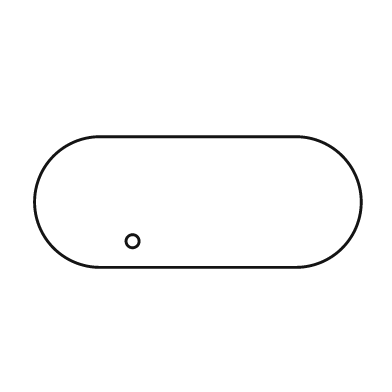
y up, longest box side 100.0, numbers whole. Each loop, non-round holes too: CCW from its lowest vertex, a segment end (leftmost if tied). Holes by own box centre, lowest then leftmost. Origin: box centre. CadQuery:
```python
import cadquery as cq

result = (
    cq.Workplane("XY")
    .moveTo(-30.0, -20.0)
    .lineTo(30.0, -20.0)
    .threePointArc((50.0, 0.0), (30.0, 20.0))
    .lineTo(-30.0, 20.0)
    .threePointArc((-50.0, 0.0), (-30.0, -20.0))
    .close()
    .moveTo(-20.0, -12.0)
    .circle(2.0)
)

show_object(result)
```